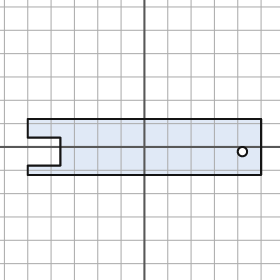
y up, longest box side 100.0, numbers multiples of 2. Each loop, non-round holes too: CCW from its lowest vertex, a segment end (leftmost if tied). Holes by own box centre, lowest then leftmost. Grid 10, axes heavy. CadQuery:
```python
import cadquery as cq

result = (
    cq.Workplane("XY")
    .moveTo(-50.0, -12.0)
    .lineTo(50.0, -12.0)
    .lineTo(50.0, 12.0)
    .lineTo(-50.0, 12.0)
    .lineTo(-50.0, 4.0)
    .lineTo(-36.0, 4.0)
    .lineTo(-36.0, -8.0)
    .lineTo(-50.0, -8.0)
    .close()
    .moveTo(42.0, -2.0)
    .circle(2.0)
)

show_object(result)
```